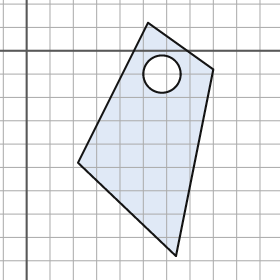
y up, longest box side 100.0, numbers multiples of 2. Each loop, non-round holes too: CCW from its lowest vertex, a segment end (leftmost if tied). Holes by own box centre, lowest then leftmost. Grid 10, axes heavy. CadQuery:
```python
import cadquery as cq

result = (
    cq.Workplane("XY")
    .moveTo(64.0, -88.0)
    .lineTo(80.0, -8.0)
    .lineTo(52.0, 12.0)
    .lineTo(22.0, -48.0)
    .close()
    .moveTo(58.0, -10.0)
    .circle(8.0)
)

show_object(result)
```